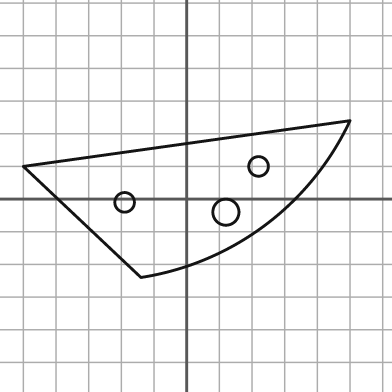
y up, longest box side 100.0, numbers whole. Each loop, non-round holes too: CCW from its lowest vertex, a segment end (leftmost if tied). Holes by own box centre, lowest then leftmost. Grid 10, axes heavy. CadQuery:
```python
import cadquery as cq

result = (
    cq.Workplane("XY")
    .moveTo(-14.0, -24.0)
    .threePointArc((24.0, -8.0), (50.0, 24.0))
    .lineTo(-50.0, 10.0)
    .close()
    .moveTo(12.0, -4.0)
    .circle(4.0)
    .moveTo(-19.0, -1.0)
    .circle(3.0)
    .moveTo(22.0, 10.0)
    .circle(3.0)
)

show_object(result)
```